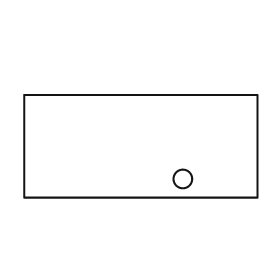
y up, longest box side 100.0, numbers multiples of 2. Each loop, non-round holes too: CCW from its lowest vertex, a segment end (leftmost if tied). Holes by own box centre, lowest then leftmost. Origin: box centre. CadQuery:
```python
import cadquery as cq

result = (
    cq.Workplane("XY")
    .moveTo(-50.0, -22.0)
    .lineTo(50.0, -22.0)
    .lineTo(50.0, 22.0)
    .lineTo(-50.0, 22.0)
    .close()
    .moveTo(18.0, -14.0)
    .circle(4.0)
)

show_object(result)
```